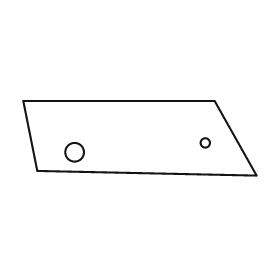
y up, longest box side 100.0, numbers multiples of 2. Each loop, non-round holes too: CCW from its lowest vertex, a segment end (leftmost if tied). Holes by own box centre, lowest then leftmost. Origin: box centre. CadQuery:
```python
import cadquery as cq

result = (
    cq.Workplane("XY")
    .moveTo(50.0, -16.0)
    .lineTo(32.0, 16.0)
    .lineTo(-50.0, 16.0)
    .lineTo(-44.0, -14.0)
    .close()
    .moveTo(-28.0, -6.0)
    .circle(4.0)
    .moveTo(28.0, -2.0)
    .circle(2.0)
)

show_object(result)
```